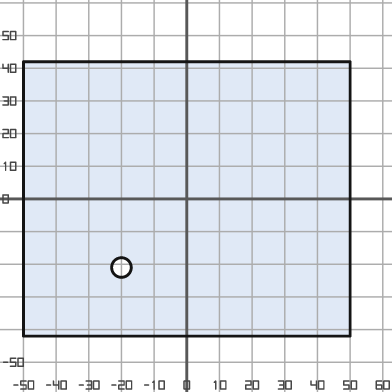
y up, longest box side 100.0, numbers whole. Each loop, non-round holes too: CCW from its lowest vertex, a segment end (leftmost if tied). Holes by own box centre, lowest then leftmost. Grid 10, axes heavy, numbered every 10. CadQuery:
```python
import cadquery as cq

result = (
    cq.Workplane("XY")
    .moveTo(-50.0, -42.0)
    .lineTo(50.0, -42.0)
    .lineTo(50.0, 42.0)
    .lineTo(-50.0, 42.0)
    .close()
    .moveTo(-20.0, -21.0)
    .circle(3.0)
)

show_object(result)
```